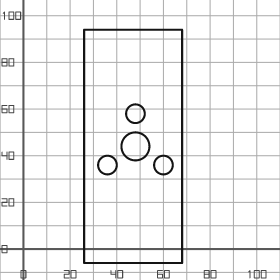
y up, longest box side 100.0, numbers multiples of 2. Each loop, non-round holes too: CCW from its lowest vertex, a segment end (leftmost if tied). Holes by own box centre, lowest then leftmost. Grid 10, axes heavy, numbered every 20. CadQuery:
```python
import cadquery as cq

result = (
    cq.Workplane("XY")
    .moveTo(26.0, -6.0)
    .lineTo(68.0, -6.0)
    .lineTo(68.0, 94.0)
    .lineTo(26.0, 94.0)
    .close()
    .moveTo(36.0, 36.0)
    .circle(4.0)
    .moveTo(60.0, 36.0)
    .circle(4.0)
    .moveTo(48.0, 44.0)
    .circle(6.0)
    .moveTo(48.0, 58.0)
    .circle(4.0)
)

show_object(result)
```